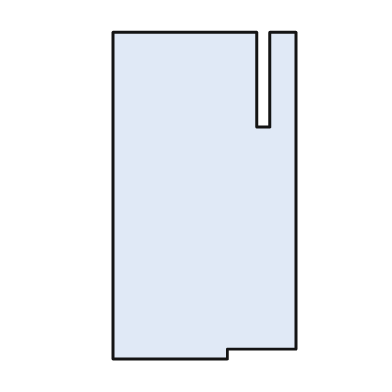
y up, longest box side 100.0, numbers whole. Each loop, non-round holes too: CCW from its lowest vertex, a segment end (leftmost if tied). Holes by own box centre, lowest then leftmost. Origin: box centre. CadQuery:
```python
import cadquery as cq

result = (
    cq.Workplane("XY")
    .moveTo(-28.0, -50.0)
    .lineTo(7.0, -50.0)
    .lineTo(7.0, -47.0)
    .lineTo(28.0, -47.0)
    .lineTo(28.0, 50.0)
    .lineTo(20.0, 50.0)
    .lineTo(20.0, 21.0)
    .lineTo(16.0, 21.0)
    .lineTo(16.0, 50.0)
    .lineTo(-28.0, 50.0)
    .close()
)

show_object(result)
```